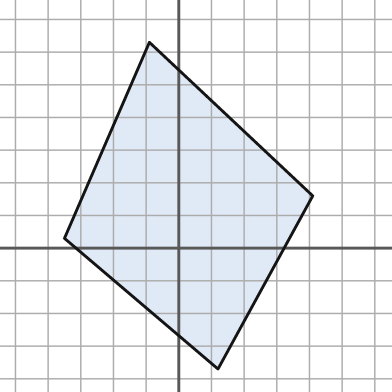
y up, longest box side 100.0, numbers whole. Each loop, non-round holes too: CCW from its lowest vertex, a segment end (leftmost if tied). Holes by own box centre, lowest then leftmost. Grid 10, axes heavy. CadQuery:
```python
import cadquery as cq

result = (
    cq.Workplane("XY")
    .moveTo(12.0, -37.0)
    .lineTo(41.0, 16.0)
    .lineTo(-9.0, 63.0)
    .lineTo(-35.0, 3.0)
    .close()
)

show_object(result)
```